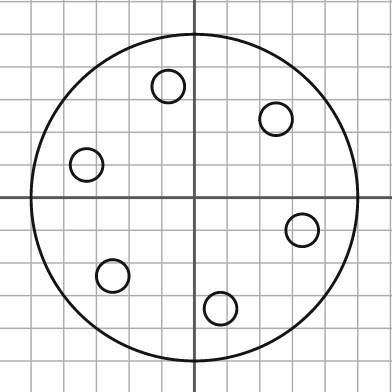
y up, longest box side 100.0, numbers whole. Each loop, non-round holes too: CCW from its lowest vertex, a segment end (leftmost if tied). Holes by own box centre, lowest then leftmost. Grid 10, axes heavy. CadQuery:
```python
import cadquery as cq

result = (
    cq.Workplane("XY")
    .moveTo(0.0, 0.0)
    .circle(50.0)
    .moveTo(8.0, -34.0)
    .circle(5.0)
    .moveTo(-25.0, -24.0)
    .circle(5.0)
    .moveTo(33.0, -10.0)
    .circle(5.0)
    .moveTo(-33.0, 10.0)
    .circle(5.0)
    .moveTo(25.0, 24.0)
    .circle(5.0)
    .moveTo(-8.0, 34.0)
    .circle(5.0)
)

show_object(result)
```